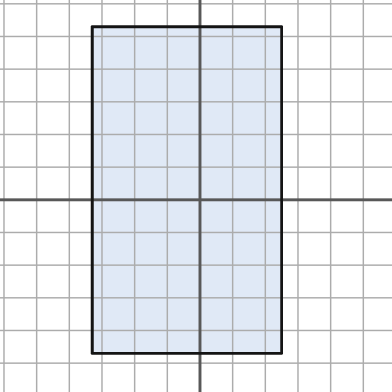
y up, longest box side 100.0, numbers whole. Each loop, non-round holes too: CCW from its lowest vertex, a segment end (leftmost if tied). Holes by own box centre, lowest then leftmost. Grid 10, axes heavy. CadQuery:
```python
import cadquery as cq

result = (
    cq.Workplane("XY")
    .moveTo(-33.0, -47.0)
    .lineTo(25.0, -47.0)
    .lineTo(25.0, 53.0)
    .lineTo(-33.0, 53.0)
    .close()
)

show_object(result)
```